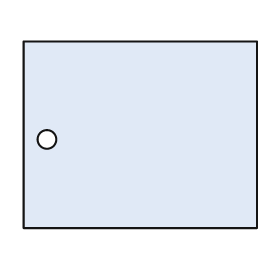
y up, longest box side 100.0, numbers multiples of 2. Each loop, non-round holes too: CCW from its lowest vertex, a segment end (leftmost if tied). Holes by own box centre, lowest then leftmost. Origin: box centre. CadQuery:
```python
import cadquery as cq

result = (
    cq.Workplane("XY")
    .moveTo(-50.0, -40.0)
    .lineTo(50.0, -40.0)
    .lineTo(50.0, 40.0)
    .lineTo(-50.0, 40.0)
    .close()
    .moveTo(-40.0, -2.0)
    .circle(4.0)
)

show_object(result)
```